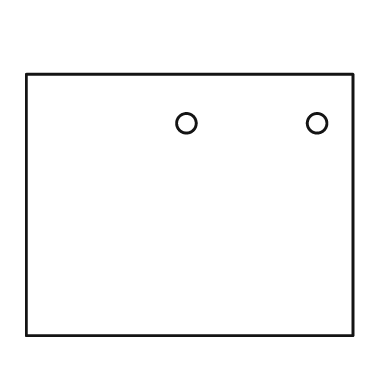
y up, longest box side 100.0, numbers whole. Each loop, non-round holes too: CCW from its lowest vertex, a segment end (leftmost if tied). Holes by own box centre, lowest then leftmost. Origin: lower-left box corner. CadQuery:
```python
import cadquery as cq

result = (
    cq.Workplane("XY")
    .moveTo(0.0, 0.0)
    .lineTo(100.0, 0.0)
    .lineTo(100.0, 80.0)
    .lineTo(0.0, 80.0)
    .close()
    .moveTo(49.0, 65.0)
    .circle(3.0)
    .moveTo(89.0, 65.0)
    .circle(3.0)
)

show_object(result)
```